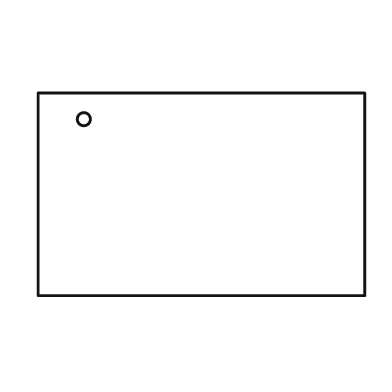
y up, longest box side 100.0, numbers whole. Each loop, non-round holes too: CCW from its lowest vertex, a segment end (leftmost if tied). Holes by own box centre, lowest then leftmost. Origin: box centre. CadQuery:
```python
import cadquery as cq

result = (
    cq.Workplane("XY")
    .moveTo(-50.0, -31.0)
    .lineTo(50.0, -31.0)
    .lineTo(50.0, 31.0)
    .lineTo(-50.0, 31.0)
    .close()
    .moveTo(-36.0, 23.0)
    .circle(2.0)
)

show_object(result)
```